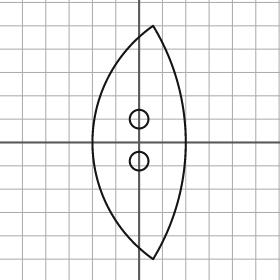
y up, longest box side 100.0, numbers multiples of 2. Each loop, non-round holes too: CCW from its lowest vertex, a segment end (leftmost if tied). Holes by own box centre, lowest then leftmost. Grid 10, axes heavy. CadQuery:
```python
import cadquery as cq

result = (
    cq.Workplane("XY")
    .moveTo(6.0, -50.0)
    .threePointArc((20.0, 0.0), (6.0, 50.0))
    .threePointArc((-20.0, 0.0), (6.0, -50.0))
    .close()
    .moveTo(0.0, -8.0)
    .circle(4.0)
    .moveTo(0.0, 10.0)
    .circle(4.0)
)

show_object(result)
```